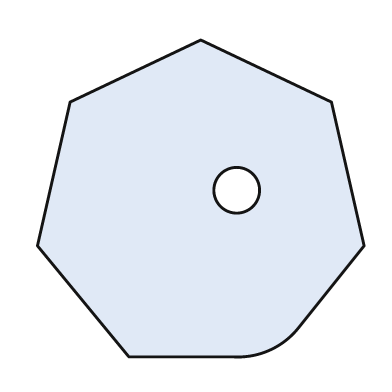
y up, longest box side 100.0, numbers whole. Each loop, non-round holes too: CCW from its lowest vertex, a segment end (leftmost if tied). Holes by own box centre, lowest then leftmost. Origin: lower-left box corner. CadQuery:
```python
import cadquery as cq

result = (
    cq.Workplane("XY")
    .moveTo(28.0, 0.0)
    .lineTo(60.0, 0.0)
    .threePointArc((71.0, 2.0), (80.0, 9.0))
    .lineTo(100.0, 34.0)
    .lineTo(90.0, 78.0)
    .lineTo(50.0, 97.0)
    .lineTo(10.0, 78.0)
    .lineTo(0.0, 34.0)
    .close()
    .moveTo(61.0, 51.0)
    .circle(7.0)
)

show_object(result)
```